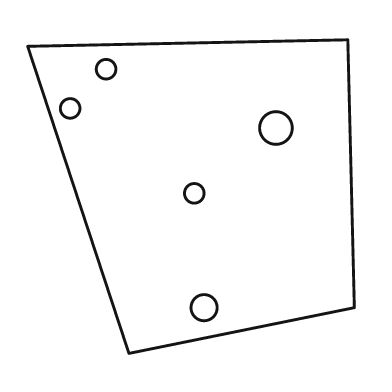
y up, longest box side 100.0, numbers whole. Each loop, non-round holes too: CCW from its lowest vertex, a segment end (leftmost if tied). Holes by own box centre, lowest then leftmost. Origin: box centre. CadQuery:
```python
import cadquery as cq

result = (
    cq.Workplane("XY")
    .moveTo(-19.0, -48.0)
    .lineTo(50.0, -34.0)
    .lineTo(48.0, 48.0)
    .lineTo(-50.0, 46.0)
    .close()
    .moveTo(4.0, -34.0)
    .circle(4.0)
    .moveTo(1.0, 1.0)
    .circle(3.0)
    .moveTo(26.0, 21.0)
    .circle(5.0)
    .moveTo(-37.0, 27.0)
    .circle(3.0)
    .moveTo(-26.0, 39.0)
    .circle(3.0)
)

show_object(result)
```